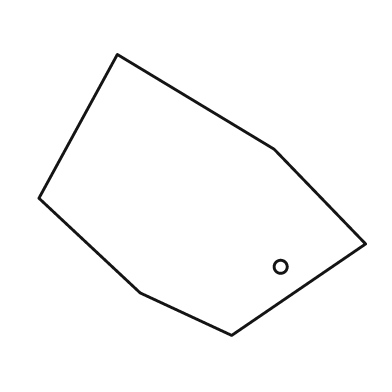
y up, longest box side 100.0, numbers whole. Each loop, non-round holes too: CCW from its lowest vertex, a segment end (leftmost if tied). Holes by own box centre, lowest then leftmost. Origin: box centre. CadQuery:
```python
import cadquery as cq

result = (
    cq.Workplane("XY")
    .moveTo(9.0, -43.0)
    .lineTo(50.0, -15.0)
    .lineTo(22.0, 14.0)
    .lineTo(-26.0, 43.0)
    .lineTo(-50.0, -1.0)
    .lineTo(-19.0, -30.0)
    .close()
    .moveTo(24.0, -22.0)
    .circle(2.0)
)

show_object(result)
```